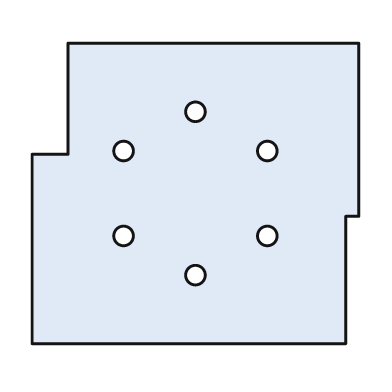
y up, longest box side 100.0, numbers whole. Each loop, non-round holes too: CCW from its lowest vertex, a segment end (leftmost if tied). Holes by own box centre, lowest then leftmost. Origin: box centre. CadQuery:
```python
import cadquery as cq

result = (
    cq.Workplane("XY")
    .moveTo(-50.0, -46.0)
    .lineTo(46.0, -46.0)
    .lineTo(46.0, -7.0)
    .lineTo(50.0, -7.0)
    .lineTo(50.0, 46.0)
    .lineTo(-39.0, 46.0)
    .lineTo(-39.0, 12.0)
    .lineTo(-50.0, 12.0)
    .close()
    .moveTo(0.0, -25.0)
    .circle(3.0)
    .moveTo(-22.0, -13.0)
    .circle(3.0)
    .moveTo(22.0, -13.0)
    .circle(3.0)
    .moveTo(-22.0, 13.0)
    .circle(3.0)
    .moveTo(22.0, 13.0)
    .circle(3.0)
    .moveTo(0.0, 25.0)
    .circle(3.0)
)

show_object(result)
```